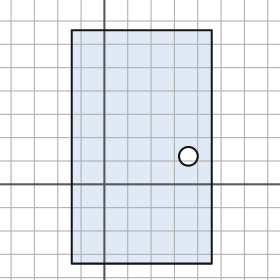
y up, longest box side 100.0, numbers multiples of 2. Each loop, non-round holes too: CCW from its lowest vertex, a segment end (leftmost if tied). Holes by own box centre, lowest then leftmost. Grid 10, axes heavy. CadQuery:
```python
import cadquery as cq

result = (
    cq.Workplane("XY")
    .moveTo(-14.0, -34.0)
    .lineTo(46.0, -34.0)
    .lineTo(46.0, 66.0)
    .lineTo(-14.0, 66.0)
    .close()
    .moveTo(36.0, 12.0)
    .circle(4.0)
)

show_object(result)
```